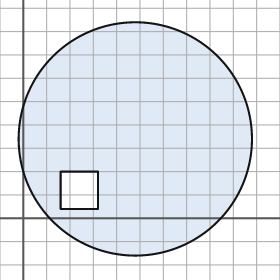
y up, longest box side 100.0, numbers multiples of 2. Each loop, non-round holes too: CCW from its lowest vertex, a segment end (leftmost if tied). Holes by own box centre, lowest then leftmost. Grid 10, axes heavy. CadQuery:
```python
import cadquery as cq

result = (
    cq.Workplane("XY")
    .moveTo(48.0, 34.0)
    .circle(50.0)
    .moveTo(16.0, 4.0)
    .lineTo(32.0, 4.0)
    .lineTo(32.0, 20.0)
    .lineTo(16.0, 20.0)
    .close()
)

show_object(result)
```